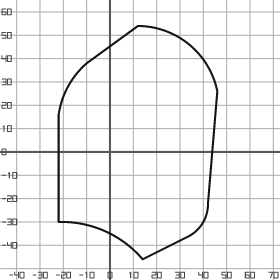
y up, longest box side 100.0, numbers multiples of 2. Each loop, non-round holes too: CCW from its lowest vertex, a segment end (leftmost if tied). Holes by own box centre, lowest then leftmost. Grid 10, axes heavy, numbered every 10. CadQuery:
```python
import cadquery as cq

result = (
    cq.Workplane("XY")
    .moveTo(14.0, -46.0)
    .lineTo(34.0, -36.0)
    .threePointArc((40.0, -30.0), (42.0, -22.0))
    .lineTo(46.0, 26.0)
    .threePointArc((34.0, 46.0), (12.0, 54.0))
    .lineTo(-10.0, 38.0)
    .threePointArc((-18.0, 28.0), (-22.0, 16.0))
    .lineTo(-22.0, -30.0)
    .threePointArc((-2.0, -34.0), (14.0, -46.0))
    .close()
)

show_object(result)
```